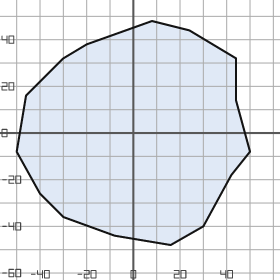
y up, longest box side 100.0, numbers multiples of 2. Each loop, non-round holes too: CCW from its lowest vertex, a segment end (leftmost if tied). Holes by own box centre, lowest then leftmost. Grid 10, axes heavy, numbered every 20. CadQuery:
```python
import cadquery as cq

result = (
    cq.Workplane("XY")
    .moveTo(16.0, -48.0)
    .lineTo(30.0, -40.0)
    .lineTo(42.0, -18.0)
    .lineTo(50.0, -8.0)
    .lineTo(44.0, 14.0)
    .lineTo(44.0, 32.0)
    .lineTo(24.0, 44.0)
    .lineTo(8.0, 48.0)
    .lineTo(-20.0, 38.0)
    .lineTo(-30.0, 32.0)
    .lineTo(-46.0, 16.0)
    .lineTo(-50.0, -8.0)
    .lineTo(-40.0, -26.0)
    .lineTo(-30.0, -36.0)
    .lineTo(-8.0, -44.0)
    .close()
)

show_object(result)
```